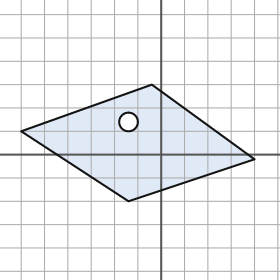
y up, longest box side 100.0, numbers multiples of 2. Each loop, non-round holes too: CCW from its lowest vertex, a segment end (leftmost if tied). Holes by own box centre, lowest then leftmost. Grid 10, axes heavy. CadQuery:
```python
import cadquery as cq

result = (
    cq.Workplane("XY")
    .moveTo(-14.0, -20.0)
    .lineTo(40.0, -2.0)
    .lineTo(-4.0, 30.0)
    .lineTo(-60.0, 10.0)
    .close()
    .moveTo(-14.0, 14.0)
    .circle(4.0)
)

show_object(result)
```